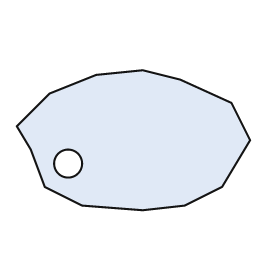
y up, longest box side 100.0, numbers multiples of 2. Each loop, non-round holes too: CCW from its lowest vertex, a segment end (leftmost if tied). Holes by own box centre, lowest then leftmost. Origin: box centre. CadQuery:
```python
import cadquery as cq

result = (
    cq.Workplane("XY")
    .moveTo(4.0, -30.0)
    .lineTo(22.0, -28.0)
    .lineTo(38.0, -20.0)
    .lineTo(50.0, 0.0)
    .lineTo(42.0, 16.0)
    .lineTo(20.0, 26.0)
    .lineTo(4.0, 30.0)
    .lineTo(-16.0, 28.0)
    .lineTo(-36.0, 20.0)
    .lineTo(-50.0, 6.0)
    .lineTo(-44.0, -4.0)
    .lineTo(-38.0, -20.0)
    .lineTo(-22.0, -28.0)
    .close()
    .moveTo(-28.0, -10.0)
    .circle(6.0)
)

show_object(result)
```